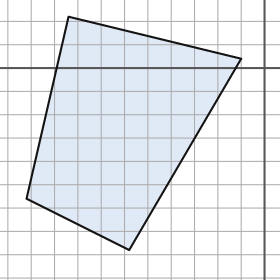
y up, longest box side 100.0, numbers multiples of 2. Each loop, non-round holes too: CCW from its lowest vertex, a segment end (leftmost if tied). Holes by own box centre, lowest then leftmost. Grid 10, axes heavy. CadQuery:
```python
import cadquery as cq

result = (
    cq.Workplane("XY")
    .moveTo(-58.0, -78.0)
    .lineTo(-10.0, 4.0)
    .lineTo(-84.0, 22.0)
    .lineTo(-102.0, -56.0)
    .close()
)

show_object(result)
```